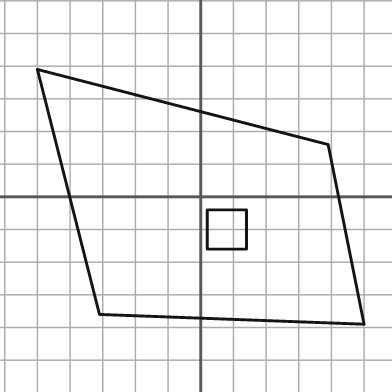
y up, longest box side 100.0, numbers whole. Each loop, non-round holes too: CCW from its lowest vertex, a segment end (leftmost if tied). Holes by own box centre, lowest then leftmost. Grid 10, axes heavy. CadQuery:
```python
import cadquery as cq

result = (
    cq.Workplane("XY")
    .moveTo(50.0, -39.0)
    .lineTo(39.0, 16.0)
    .lineTo(-50.0, 39.0)
    .lineTo(-31.0, -36.0)
    .close()
    .moveTo(2.0, -16.0)
    .lineTo(14.0, -16.0)
    .lineTo(14.0, -4.0)
    .lineTo(2.0, -4.0)
    .close()
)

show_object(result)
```